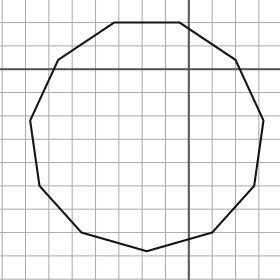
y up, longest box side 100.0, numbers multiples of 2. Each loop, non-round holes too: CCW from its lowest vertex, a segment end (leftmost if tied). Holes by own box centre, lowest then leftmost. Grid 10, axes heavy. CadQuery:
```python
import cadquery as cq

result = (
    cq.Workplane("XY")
    .moveTo(-18.0, -78.0)
    .lineTo(10.0, -70.0)
    .lineTo(28.0, -50.0)
    .lineTo(32.0, -22.0)
    .lineTo(20.0, 4.0)
    .lineTo(-4.0, 20.0)
    .lineTo(-32.0, 20.0)
    .lineTo(-56.0, 4.0)
    .lineTo(-68.0, -22.0)
    .lineTo(-64.0, -50.0)
    .lineTo(-46.0, -70.0)
    .close()
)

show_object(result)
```